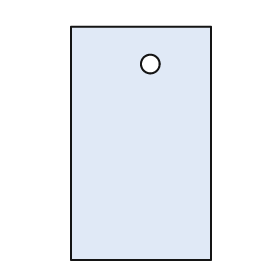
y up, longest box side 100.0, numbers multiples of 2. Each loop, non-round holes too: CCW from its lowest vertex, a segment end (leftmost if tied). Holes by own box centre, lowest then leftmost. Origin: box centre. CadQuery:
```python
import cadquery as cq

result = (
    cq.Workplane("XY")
    .moveTo(-30.0, -50.0)
    .lineTo(30.0, -50.0)
    .lineTo(30.0, 50.0)
    .lineTo(-30.0, 50.0)
    .close()
    .moveTo(4.0, 34.0)
    .circle(4.0)
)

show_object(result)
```